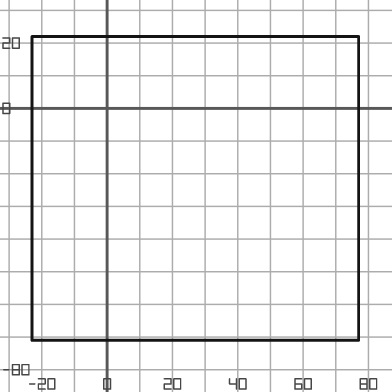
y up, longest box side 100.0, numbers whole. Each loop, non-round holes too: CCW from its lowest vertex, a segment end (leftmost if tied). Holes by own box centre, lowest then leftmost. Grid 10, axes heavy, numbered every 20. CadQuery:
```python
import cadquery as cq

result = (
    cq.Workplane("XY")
    .moveTo(-23.0, -71.0)
    .lineTo(77.0, -71.0)
    .lineTo(77.0, 22.0)
    .lineTo(-23.0, 22.0)
    .close()
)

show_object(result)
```